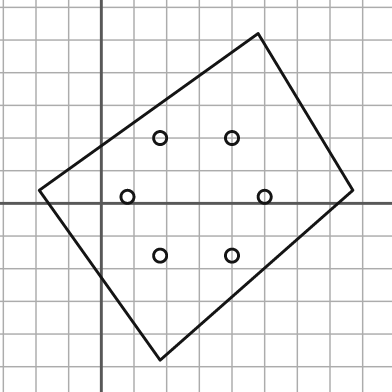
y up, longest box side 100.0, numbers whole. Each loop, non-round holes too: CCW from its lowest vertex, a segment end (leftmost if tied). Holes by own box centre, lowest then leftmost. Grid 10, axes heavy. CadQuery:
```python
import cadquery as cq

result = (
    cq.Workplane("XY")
    .moveTo(18.0, -48.0)
    .lineTo(77.0, 4.0)
    .lineTo(48.0, 52.0)
    .lineTo(-19.0, 4.0)
    .close()
    .moveTo(18.0, -16.0)
    .circle(2.0)
    .moveTo(40.0, -16.0)
    .circle(2.0)
    .moveTo(8.0, 2.0)
    .circle(2.0)
    .moveTo(50.0, 2.0)
    .circle(2.0)
    .moveTo(18.0, 20.0)
    .circle(2.0)
    .moveTo(40.0, 20.0)
    .circle(2.0)
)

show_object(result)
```